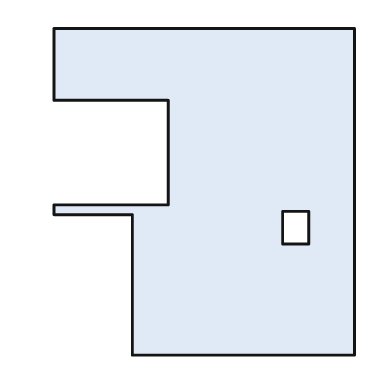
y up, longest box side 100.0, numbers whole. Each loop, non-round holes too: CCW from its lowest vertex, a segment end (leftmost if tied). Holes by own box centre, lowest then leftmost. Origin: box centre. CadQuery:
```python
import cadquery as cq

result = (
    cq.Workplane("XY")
    .moveTo(-22.0, -50.0)
    .lineTo(46.0, -50.0)
    .lineTo(46.0, 50.0)
    .lineTo(-46.0, 50.0)
    .lineTo(-46.0, 28.0)
    .lineTo(-11.0, 28.0)
    .lineTo(-11.0, -4.0)
    .lineTo(-46.0, -4.0)
    .lineTo(-46.0, -7.0)
    .lineTo(-22.0, -7.0)
    .close()
    .moveTo(24.0, -16.0)
    .lineTo(32.0, -16.0)
    .lineTo(32.0, -6.0)
    .lineTo(24.0, -6.0)
    .close()
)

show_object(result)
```